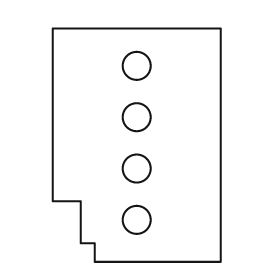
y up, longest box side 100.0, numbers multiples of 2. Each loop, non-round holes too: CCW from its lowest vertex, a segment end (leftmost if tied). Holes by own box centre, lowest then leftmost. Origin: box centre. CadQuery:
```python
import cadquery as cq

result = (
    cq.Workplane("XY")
    .moveTo(-18.0, -50.0)
    .lineTo(36.0, -50.0)
    .lineTo(36.0, 50.0)
    .lineTo(-36.0, 50.0)
    .lineTo(-36.0, -24.0)
    .lineTo(-24.0, -24.0)
    .lineTo(-24.0, -42.0)
    .lineTo(-18.0, -42.0)
    .close()
    .moveTo(0.0, -32.0)
    .circle(6.0)
    .moveTo(0.0, -10.0)
    .circle(6.0)
    .moveTo(0.0, 12.0)
    .circle(6.0)
    .moveTo(0.0, 34.0)
    .circle(6.0)
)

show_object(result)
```